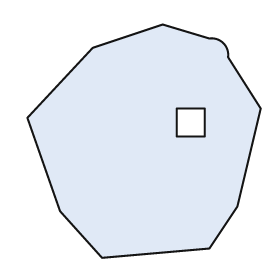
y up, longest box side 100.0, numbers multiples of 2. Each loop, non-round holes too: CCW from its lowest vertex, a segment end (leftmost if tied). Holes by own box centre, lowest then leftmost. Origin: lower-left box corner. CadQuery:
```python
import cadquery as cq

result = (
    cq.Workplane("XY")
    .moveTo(32.0, 0.0)
    .lineTo(78.0, 4.0)
    .lineTo(90.0, 22.0)
    .lineTo(100.0, 64.0)
    .lineTo(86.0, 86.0)
    .threePointArc((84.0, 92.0), (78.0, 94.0))
    .lineTo(58.0, 100.0)
    .lineTo(28.0, 90.0)
    .lineTo(0.0, 60.0)
    .lineTo(14.0, 20.0)
    .close()
    .moveTo(64.0, 52.0)
    .lineTo(76.0, 52.0)
    .lineTo(76.0, 64.0)
    .lineTo(64.0, 64.0)
    .close()
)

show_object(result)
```